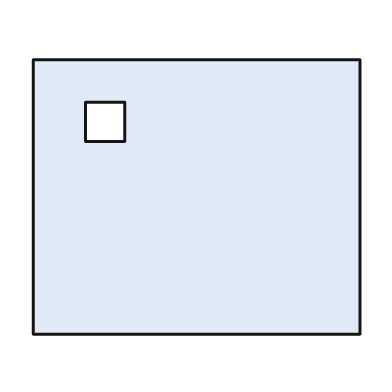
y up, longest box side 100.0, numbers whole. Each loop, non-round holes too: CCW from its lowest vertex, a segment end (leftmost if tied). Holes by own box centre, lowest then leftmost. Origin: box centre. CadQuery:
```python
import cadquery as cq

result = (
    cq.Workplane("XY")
    .moveTo(-50.0, -42.0)
    .lineTo(50.0, -42.0)
    .lineTo(50.0, 42.0)
    .lineTo(-50.0, 42.0)
    .close()
    .moveTo(-34.0, 17.0)
    .lineTo(-22.0, 17.0)
    .lineTo(-22.0, 29.0)
    .lineTo(-34.0, 29.0)
    .close()
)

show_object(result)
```